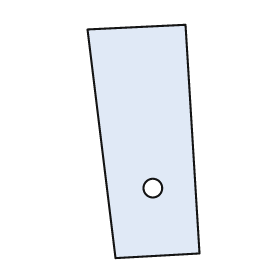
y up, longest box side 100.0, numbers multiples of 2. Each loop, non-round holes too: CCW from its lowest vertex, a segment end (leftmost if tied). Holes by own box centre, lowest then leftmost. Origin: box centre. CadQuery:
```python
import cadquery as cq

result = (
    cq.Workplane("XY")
    .moveTo(-12.0, -50.0)
    .lineTo(24.0, -48.0)
    .lineTo(18.0, 50.0)
    .lineTo(-24.0, 48.0)
    .close()
    .moveTo(4.0, -20.0)
    .circle(4.0)
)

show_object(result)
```